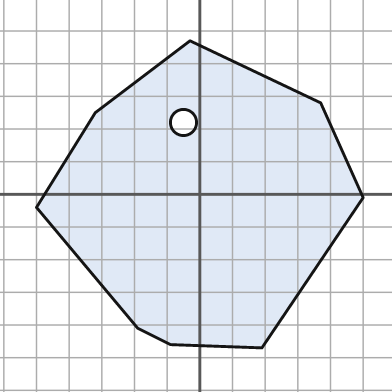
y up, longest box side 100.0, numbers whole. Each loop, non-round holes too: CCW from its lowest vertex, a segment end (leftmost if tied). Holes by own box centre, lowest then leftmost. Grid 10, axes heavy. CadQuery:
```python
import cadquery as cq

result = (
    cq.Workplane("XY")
    .moveTo(19.0, -47.0)
    .lineTo(50.0, -1.0)
    .lineTo(37.0, 28.0)
    .lineTo(-3.0, 47.0)
    .lineTo(-32.0, 25.0)
    .lineTo(-50.0, -4.0)
    .lineTo(-19.0, -41.0)
    .lineTo(-9.0, -46.0)
    .close()
    .moveTo(-5.0, 22.0)
    .circle(4.0)
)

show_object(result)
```